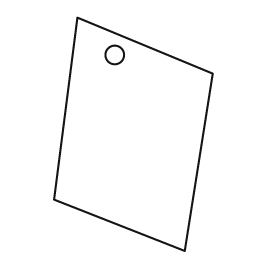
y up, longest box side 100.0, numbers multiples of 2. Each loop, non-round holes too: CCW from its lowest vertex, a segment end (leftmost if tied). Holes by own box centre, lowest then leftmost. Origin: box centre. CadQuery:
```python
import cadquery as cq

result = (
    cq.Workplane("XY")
    .moveTo(22.0, -50.0)
    .lineTo(34.0, 26.0)
    .lineTo(-24.0, 50.0)
    .lineTo(-34.0, -28.0)
    .close()
    .moveTo(-8.0, 34.0)
    .circle(4.0)
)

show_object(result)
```